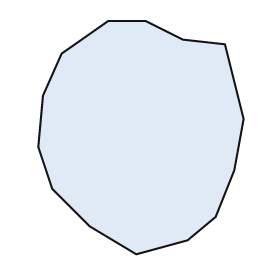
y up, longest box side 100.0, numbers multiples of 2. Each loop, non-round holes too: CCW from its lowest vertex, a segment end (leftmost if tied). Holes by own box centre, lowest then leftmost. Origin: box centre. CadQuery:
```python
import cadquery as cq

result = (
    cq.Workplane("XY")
    .moveTo(-2.0, -50.0)
    .lineTo(20.0, -44.0)
    .lineTo(32.0, -34.0)
    .lineTo(40.0, -14.0)
    .lineTo(44.0, 8.0)
    .lineTo(36.0, 40.0)
    .lineTo(18.0, 42.0)
    .lineTo(2.0, 50.0)
    .lineTo(-14.0, 50.0)
    .lineTo(-34.0, 36.0)
    .lineTo(-42.0, 18.0)
    .lineTo(-44.0, -4.0)
    .lineTo(-38.0, -22.0)
    .lineTo(-22.0, -38.0)
    .close()
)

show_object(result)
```